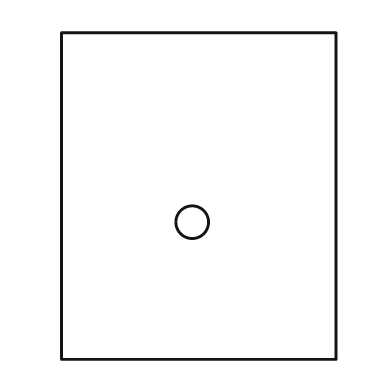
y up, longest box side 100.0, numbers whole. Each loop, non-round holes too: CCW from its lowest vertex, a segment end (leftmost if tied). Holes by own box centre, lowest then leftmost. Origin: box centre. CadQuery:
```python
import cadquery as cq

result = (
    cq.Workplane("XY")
    .moveTo(-42.0, -50.0)
    .lineTo(42.0, -50.0)
    .lineTo(42.0, 50.0)
    .lineTo(-42.0, 50.0)
    .close()
    .moveTo(-2.0, -8.0)
    .circle(5.0)
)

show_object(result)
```